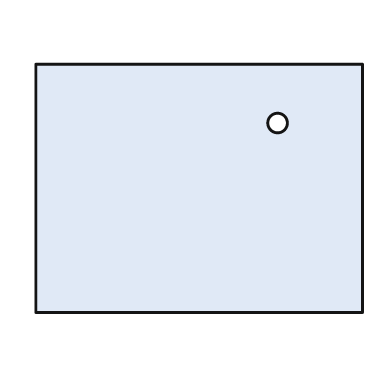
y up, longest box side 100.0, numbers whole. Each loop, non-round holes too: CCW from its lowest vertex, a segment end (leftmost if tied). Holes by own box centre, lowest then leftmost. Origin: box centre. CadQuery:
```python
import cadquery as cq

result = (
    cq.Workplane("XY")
    .moveTo(-50.0, -38.0)
    .lineTo(50.0, -38.0)
    .lineTo(50.0, 38.0)
    .lineTo(-50.0, 38.0)
    .close()
    .moveTo(24.0, 20.0)
    .circle(3.0)
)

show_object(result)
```